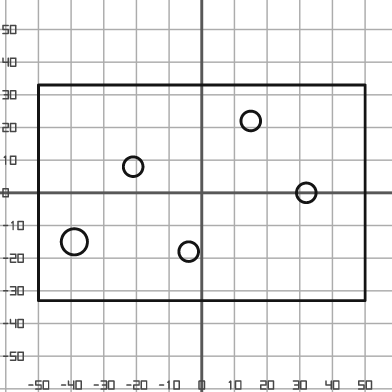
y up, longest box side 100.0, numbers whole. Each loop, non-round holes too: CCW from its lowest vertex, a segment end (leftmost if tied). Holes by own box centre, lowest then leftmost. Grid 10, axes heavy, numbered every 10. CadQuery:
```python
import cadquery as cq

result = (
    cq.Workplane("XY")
    .moveTo(-50.0, -33.0)
    .lineTo(50.0, -33.0)
    .lineTo(50.0, 33.0)
    .lineTo(-50.0, 33.0)
    .close()
    .moveTo(-4.0, -18.0)
    .circle(3.0)
    .moveTo(-39.0, -15.0)
    .circle(4.0)
    .moveTo(32.0, 0.0)
    .circle(3.0)
    .moveTo(-21.0, 8.0)
    .circle(3.0)
    .moveTo(15.0, 22.0)
    .circle(3.0)
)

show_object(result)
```